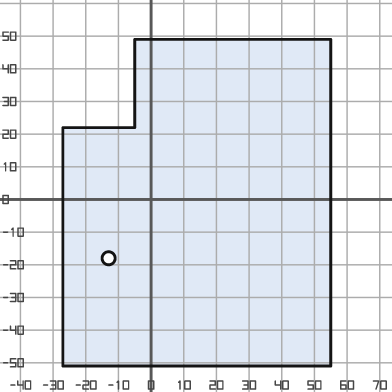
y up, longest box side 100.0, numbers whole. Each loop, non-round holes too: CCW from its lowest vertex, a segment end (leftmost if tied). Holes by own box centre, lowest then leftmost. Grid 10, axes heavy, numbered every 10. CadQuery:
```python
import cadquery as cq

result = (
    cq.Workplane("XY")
    .moveTo(-27.0, -51.0)
    .lineTo(55.0, -51.0)
    .lineTo(55.0, 49.0)
    .lineTo(-5.0, 49.0)
    .lineTo(-5.0, 22.0)
    .lineTo(-27.0, 22.0)
    .close()
    .moveTo(-13.0, -18.0)
    .circle(2.0)
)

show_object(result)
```